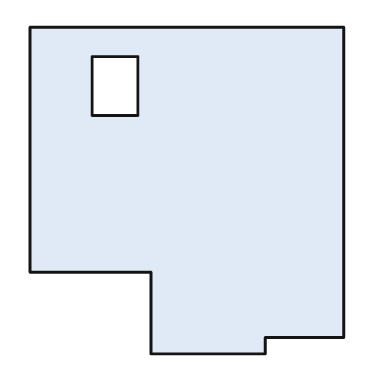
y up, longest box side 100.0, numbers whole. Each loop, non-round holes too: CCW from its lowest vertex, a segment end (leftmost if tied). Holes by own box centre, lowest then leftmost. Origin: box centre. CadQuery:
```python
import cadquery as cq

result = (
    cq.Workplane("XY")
    .moveTo(-11.0, -50.0)
    .lineTo(24.0, -50.0)
    .lineTo(24.0, -45.0)
    .lineTo(48.0, -45.0)
    .lineTo(48.0, 50.0)
    .lineTo(-48.0, 50.0)
    .lineTo(-48.0, -25.0)
    .lineTo(-11.0, -25.0)
    .close()
    .moveTo(-29.0, 23.0)
    .lineTo(-15.0, 23.0)
    .lineTo(-15.0, 41.0)
    .lineTo(-29.0, 41.0)
    .close()
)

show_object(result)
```